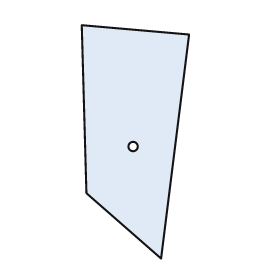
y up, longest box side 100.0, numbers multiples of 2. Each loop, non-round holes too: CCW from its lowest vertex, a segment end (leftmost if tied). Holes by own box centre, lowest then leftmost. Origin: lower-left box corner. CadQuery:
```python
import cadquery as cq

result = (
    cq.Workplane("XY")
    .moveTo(34.0, 0.0)
    .lineTo(46.0, 96.0)
    .lineTo(0.0, 100.0)
    .lineTo(2.0, 28.0)
    .close()
    .moveTo(22.0, 48.0)
    .circle(2.0)
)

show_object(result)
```